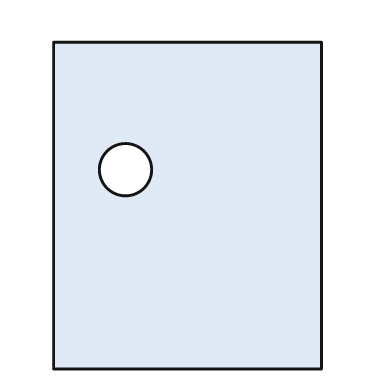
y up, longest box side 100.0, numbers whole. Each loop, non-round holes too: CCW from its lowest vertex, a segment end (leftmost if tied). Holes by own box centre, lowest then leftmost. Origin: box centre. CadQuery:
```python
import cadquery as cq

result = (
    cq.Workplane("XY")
    .moveTo(-41.0, -50.0)
    .lineTo(41.0, -50.0)
    .lineTo(41.0, 50.0)
    .lineTo(-41.0, 50.0)
    .close()
    .moveTo(-19.0, 11.0)
    .circle(8.0)
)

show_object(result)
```